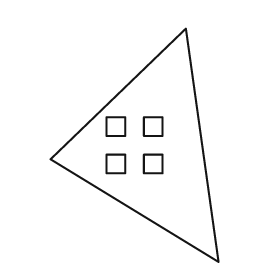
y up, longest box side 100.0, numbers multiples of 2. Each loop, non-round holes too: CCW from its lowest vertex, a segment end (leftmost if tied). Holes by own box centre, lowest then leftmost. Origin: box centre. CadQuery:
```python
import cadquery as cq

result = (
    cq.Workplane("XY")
    .moveTo(36.0, -50.0)
    .lineTo(22.0, 50.0)
    .lineTo(-36.0, -6.0)
    .close()
    .moveTo(-12.0, -12.0)
    .lineTo(-4.0, -12.0)
    .lineTo(-4.0, -4.0)
    .lineTo(-12.0, -4.0)
    .close()
    .moveTo(4.0, -12.0)
    .lineTo(12.0, -12.0)
    .lineTo(12.0, -4.0)
    .lineTo(4.0, -4.0)
    .close()
    .moveTo(-12.0, 4.0)
    .lineTo(-4.0, 4.0)
    .lineTo(-4.0, 12.0)
    .lineTo(-12.0, 12.0)
    .close()
    .moveTo(4.0, 4.0)
    .lineTo(12.0, 4.0)
    .lineTo(12.0, 12.0)
    .lineTo(4.0, 12.0)
    .close()
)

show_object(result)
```